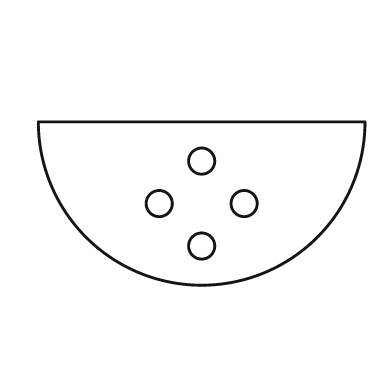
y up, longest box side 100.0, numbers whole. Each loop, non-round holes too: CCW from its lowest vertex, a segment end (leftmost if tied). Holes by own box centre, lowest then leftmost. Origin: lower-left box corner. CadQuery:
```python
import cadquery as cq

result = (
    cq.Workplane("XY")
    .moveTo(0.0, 50.0)
    .threePointArc((50.0, 0.0), (100.0, 50.0))
    .close()
    .moveTo(50.0, 12.0)
    .circle(4.0)
    .moveTo(37.0, 25.0)
    .circle(4.0)
    .moveTo(63.0, 25.0)
    .circle(4.0)
    .moveTo(50.0, 38.0)
    .circle(4.0)
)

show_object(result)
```